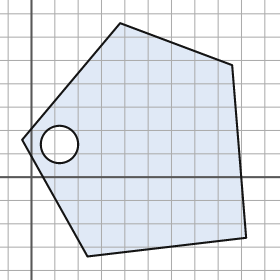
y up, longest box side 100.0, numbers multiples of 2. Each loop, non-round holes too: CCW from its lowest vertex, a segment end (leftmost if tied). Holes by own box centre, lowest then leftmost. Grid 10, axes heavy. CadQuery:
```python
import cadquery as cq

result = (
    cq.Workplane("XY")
    .moveTo(24.0, -34.0)
    .lineTo(92.0, -26.0)
    .lineTo(86.0, 48.0)
    .lineTo(38.0, 66.0)
    .lineTo(-4.0, 16.0)
    .close()
    .moveTo(12.0, 14.0)
    .circle(8.0)
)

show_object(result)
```